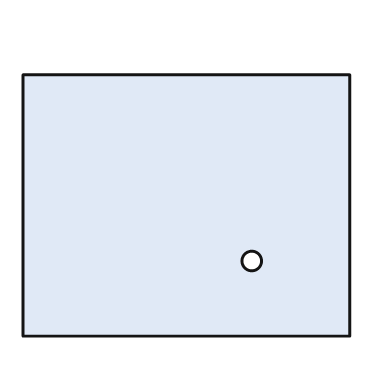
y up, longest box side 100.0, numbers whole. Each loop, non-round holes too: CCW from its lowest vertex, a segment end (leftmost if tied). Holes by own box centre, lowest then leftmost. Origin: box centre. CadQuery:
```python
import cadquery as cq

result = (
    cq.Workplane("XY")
    .moveTo(-50.0, -40.0)
    .lineTo(50.0, -40.0)
    .lineTo(50.0, 40.0)
    .lineTo(-50.0, 40.0)
    .close()
    .moveTo(20.0, -17.0)
    .circle(3.0)
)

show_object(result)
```